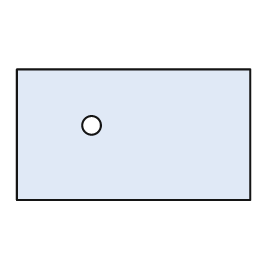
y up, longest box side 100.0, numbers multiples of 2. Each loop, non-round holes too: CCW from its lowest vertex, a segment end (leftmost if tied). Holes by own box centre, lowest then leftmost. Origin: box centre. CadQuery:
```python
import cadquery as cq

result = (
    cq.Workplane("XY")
    .moveTo(-50.0, -28.0)
    .lineTo(50.0, -28.0)
    .lineTo(50.0, 28.0)
    .lineTo(-50.0, 28.0)
    .close()
    .moveTo(-18.0, 4.0)
    .circle(4.0)
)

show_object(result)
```